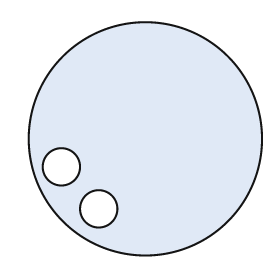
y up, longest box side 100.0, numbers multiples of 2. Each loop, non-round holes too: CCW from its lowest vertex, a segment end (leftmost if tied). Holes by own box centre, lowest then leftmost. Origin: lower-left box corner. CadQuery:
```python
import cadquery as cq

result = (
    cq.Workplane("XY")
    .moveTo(50.0, 50.0)
    .circle(50.0)
    .moveTo(30.0, 20.0)
    .circle(8.0)
    .moveTo(14.0, 38.0)
    .circle(8.0)
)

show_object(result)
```